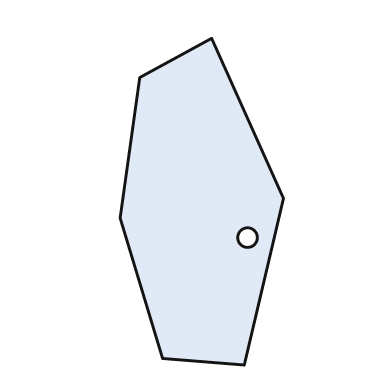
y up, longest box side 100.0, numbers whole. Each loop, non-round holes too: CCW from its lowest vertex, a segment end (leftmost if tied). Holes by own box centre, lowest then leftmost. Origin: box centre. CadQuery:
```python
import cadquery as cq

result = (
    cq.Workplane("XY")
    .moveTo(13.0, -50.0)
    .lineTo(25.0, 1.0)
    .lineTo(3.0, 50.0)
    .lineTo(-19.0, 38.0)
    .lineTo(-25.0, -5.0)
    .lineTo(-12.0, -48.0)
    .close()
    .moveTo(14.0, -11.0)
    .circle(3.0)
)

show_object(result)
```